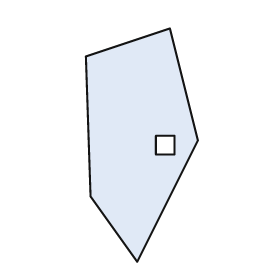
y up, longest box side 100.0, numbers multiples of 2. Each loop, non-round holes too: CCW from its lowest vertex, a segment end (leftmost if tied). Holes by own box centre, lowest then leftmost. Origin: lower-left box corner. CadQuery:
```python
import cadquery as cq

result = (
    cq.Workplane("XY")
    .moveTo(22.0, 0.0)
    .lineTo(48.0, 52.0)
    .lineTo(36.0, 100.0)
    .lineTo(0.0, 88.0)
    .lineTo(2.0, 28.0)
    .close()
    .moveTo(30.0, 46.0)
    .lineTo(38.0, 46.0)
    .lineTo(38.0, 54.0)
    .lineTo(30.0, 54.0)
    .close()
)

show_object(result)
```